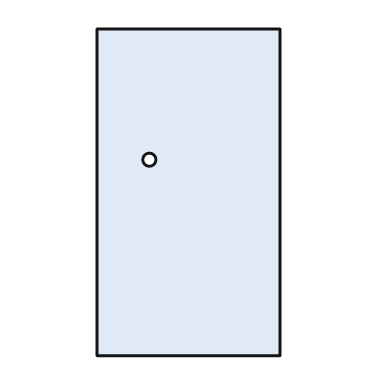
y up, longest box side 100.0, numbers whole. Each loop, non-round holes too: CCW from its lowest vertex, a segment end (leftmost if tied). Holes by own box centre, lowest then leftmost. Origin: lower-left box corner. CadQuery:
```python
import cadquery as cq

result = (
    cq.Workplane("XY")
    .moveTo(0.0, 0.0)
    .lineTo(56.0, 0.0)
    .lineTo(56.0, 100.0)
    .lineTo(0.0, 100.0)
    .close()
    .moveTo(16.0, 60.0)
    .circle(2.0)
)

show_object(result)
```